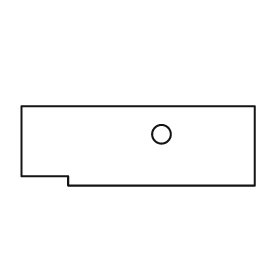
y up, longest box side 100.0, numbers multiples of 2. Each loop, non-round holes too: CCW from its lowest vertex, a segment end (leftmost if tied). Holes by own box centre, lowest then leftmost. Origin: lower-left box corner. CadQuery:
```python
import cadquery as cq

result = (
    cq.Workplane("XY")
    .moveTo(20.0, 0.0)
    .lineTo(100.0, 0.0)
    .lineTo(100.0, 34.0)
    .lineTo(0.0, 34.0)
    .lineTo(0.0, 4.0)
    .lineTo(20.0, 4.0)
    .close()
    .moveTo(60.0, 22.0)
    .circle(4.0)
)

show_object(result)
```